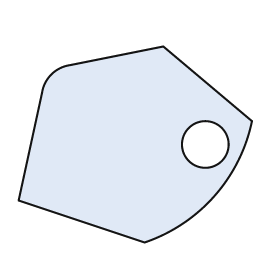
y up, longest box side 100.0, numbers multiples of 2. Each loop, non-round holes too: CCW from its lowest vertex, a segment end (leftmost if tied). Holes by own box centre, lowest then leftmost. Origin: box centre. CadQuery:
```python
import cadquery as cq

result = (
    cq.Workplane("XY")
    .moveTo(4.0, -42.0)
    .threePointArc((34.0, -22.0), (50.0, 10.0))
    .lineTo(12.0, 42.0)
    .lineTo(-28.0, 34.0)
    .threePointArc((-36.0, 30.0), (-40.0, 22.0))
    .lineTo(-50.0, -24.0)
    .close()
    .moveTo(30.0, 0.0)
    .circle(10.0)
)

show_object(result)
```